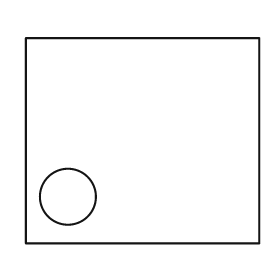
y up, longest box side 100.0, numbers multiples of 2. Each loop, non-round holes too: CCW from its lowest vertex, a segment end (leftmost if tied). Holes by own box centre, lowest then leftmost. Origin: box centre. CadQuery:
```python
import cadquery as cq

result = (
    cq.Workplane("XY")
    .moveTo(-50.0, -44.0)
    .lineTo(50.0, -44.0)
    .lineTo(50.0, 44.0)
    .lineTo(-50.0, 44.0)
    .close()
    .moveTo(-32.0, -24.0)
    .circle(12.0)
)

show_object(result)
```